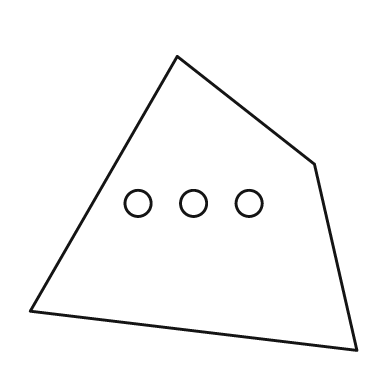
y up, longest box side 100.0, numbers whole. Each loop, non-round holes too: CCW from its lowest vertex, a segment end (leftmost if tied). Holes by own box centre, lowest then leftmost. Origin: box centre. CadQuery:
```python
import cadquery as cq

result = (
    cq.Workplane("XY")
    .moveTo(50.0, -45.0)
    .lineTo(37.0, 12.0)
    .lineTo(-5.0, 45.0)
    .lineTo(-50.0, -33.0)
    .close()
    .moveTo(-17.0, 0.0)
    .circle(4.0)
    .moveTo(0.0, 0.0)
    .circle(4.0)
    .moveTo(17.0, 0.0)
    .circle(4.0)
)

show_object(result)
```